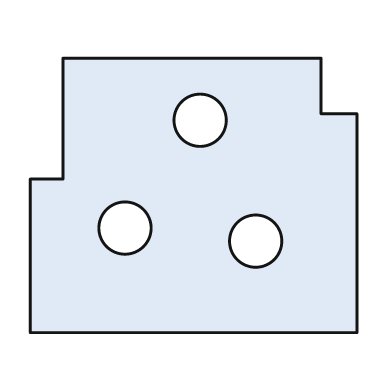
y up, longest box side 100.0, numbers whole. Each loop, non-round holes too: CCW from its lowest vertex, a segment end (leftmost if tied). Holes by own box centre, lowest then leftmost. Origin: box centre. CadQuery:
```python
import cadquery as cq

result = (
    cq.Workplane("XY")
    .moveTo(-50.0, -42.0)
    .lineTo(50.0, -42.0)
    .lineTo(50.0, 25.0)
    .lineTo(39.0, 25.0)
    .lineTo(39.0, 42.0)
    .lineTo(-40.0, 42.0)
    .lineTo(-40.0, 5.0)
    .lineTo(-50.0, 5.0)
    .close()
    .moveTo(19.0, -14.0)
    .circle(8.0)
    .moveTo(-21.0, -10.0)
    .circle(8.0)
    .moveTo(2.0, 23.0)
    .circle(8.0)
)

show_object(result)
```